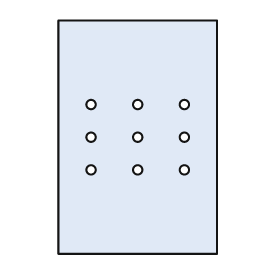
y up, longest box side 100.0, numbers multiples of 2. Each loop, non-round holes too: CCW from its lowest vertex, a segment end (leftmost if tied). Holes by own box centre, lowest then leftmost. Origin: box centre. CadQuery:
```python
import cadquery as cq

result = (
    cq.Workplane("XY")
    .moveTo(-34.0, -50.0)
    .lineTo(34.0, -50.0)
    .lineTo(34.0, 50.0)
    .lineTo(-34.0, 50.0)
    .close()
    .moveTo(-20.0, -14.0)
    .circle(2.0)
    .moveTo(0.0, -14.0)
    .circle(2.0)
    .moveTo(20.0, -14.0)
    .circle(2.0)
    .moveTo(-20.0, 0.0)
    .circle(2.0)
    .moveTo(0.0, 0.0)
    .circle(2.0)
    .moveTo(20.0, 0.0)
    .circle(2.0)
    .moveTo(-20.0, 14.0)
    .circle(2.0)
    .moveTo(0.0, 14.0)
    .circle(2.0)
    .moveTo(20.0, 14.0)
    .circle(2.0)
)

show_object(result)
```